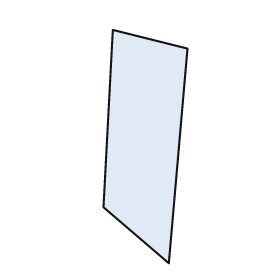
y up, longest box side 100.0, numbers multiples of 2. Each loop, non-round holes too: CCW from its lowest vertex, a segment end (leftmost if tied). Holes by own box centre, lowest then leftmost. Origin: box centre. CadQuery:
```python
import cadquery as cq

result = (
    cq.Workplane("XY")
    .moveTo(10.0, -50.0)
    .lineTo(18.0, 42.0)
    .lineTo(-14.0, 50.0)
    .lineTo(-18.0, -26.0)
    .close()
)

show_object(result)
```